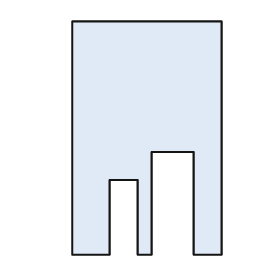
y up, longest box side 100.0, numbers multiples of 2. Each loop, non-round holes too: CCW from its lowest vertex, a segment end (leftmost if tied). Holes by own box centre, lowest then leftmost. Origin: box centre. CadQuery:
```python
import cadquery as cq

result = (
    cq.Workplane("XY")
    .moveTo(-32.0, -50.0)
    .lineTo(-16.0, -50.0)
    .lineTo(-16.0, -18.0)
    .lineTo(-4.0, -18.0)
    .lineTo(-4.0, -50.0)
    .lineTo(2.0, -50.0)
    .lineTo(2.0, -6.0)
    .lineTo(20.0, -6.0)
    .lineTo(20.0, -50.0)
    .lineTo(32.0, -50.0)
    .lineTo(32.0, 50.0)
    .lineTo(-32.0, 50.0)
    .close()
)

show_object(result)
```